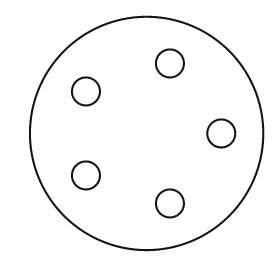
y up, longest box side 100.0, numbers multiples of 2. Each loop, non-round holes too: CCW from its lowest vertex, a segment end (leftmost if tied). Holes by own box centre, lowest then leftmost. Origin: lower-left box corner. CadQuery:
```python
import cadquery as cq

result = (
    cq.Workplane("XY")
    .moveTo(50.0, 50.0)
    .circle(50.0)
    .moveTo(60.0, 20.0)
    .circle(6.0)
    .moveTo(24.0, 32.0)
    .circle(6.0)
    .moveTo(82.0, 50.0)
    .circle(6.0)
    .moveTo(24.0, 68.0)
    .circle(6.0)
    .moveTo(60.0, 80.0)
    .circle(6.0)
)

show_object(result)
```